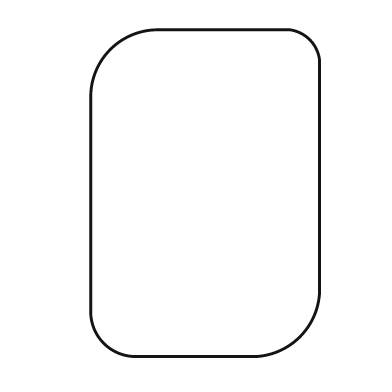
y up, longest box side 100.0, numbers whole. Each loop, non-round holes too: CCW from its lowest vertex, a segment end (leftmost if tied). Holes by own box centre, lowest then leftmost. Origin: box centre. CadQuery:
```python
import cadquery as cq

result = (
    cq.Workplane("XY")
    .moveTo(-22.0, -50.0)
    .lineTo(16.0, -50.0)
    .threePointArc((29.0, -44.0), (35.0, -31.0))
    .lineTo(35.0, 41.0)
    .threePointArc((32.0, 47.0), (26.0, 50.0))
    .lineTo(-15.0, 50.0)
    .threePointArc((-29.0, 44.0), (-35.0, 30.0))
    .lineTo(-35.0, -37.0)
    .threePointArc((-31.0, -46.0), (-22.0, -50.0))
    .close()
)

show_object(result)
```